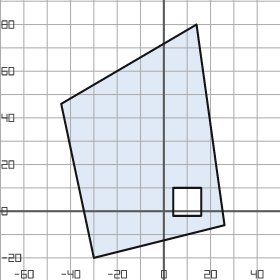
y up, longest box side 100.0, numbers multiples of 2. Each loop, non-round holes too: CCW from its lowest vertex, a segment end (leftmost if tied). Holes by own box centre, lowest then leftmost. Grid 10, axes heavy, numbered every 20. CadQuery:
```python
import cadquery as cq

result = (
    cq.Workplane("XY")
    .moveTo(-30.0, -20.0)
    .lineTo(26.0, -6.0)
    .lineTo(14.0, 80.0)
    .lineTo(-44.0, 46.0)
    .close()
    .moveTo(4.0, -2.0)
    .lineTo(16.0, -2.0)
    .lineTo(16.0, 10.0)
    .lineTo(4.0, 10.0)
    .close()
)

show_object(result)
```